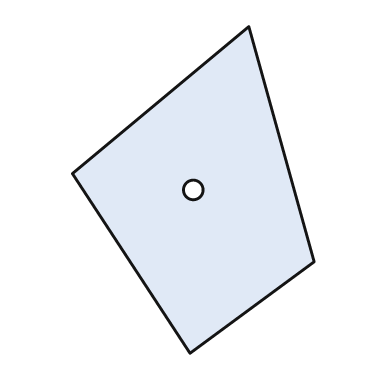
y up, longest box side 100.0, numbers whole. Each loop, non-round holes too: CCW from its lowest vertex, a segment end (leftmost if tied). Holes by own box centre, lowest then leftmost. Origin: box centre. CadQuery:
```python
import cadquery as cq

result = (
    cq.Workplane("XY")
    .moveTo(-1.0, -50.0)
    .lineTo(37.0, -22.0)
    .lineTo(17.0, 50.0)
    .lineTo(-37.0, 5.0)
    .close()
    .moveTo(0.0, 0.0)
    .circle(3.0)
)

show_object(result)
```